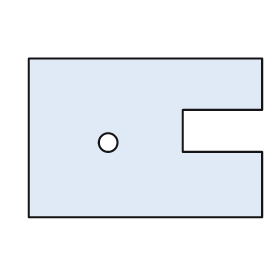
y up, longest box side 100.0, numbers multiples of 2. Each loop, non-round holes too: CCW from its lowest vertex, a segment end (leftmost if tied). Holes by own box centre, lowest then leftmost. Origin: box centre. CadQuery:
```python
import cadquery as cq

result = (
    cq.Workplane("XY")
    .moveTo(-50.0, -34.0)
    .lineTo(50.0, -34.0)
    .lineTo(50.0, -6.0)
    .lineTo(16.0, -6.0)
    .lineTo(16.0, 12.0)
    .lineTo(50.0, 12.0)
    .lineTo(50.0, 34.0)
    .lineTo(-50.0, 34.0)
    .close()
    .moveTo(-16.0, -2.0)
    .circle(4.0)
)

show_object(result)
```